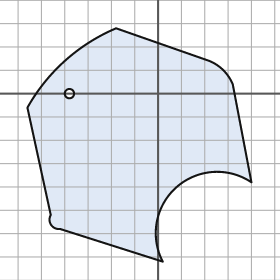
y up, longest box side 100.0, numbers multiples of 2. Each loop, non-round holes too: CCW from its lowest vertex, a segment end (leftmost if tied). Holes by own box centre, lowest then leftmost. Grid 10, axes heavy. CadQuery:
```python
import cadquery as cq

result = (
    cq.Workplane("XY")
    .moveTo(2.0, -72.0)
    .threePointArc((8.0, -40.0), (40.0, -38.0))
    .lineTo(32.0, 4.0)
    .threePointArc((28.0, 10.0), (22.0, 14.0))
    .lineTo(-18.0, 28.0)
    .threePointArc((-40.0, 14.0), (-56.0, -6.0))
    .lineTo(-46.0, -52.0)
    .threePointArc((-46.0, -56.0), (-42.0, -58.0))
    .close()
    .moveTo(-38.0, 0.0)
    .circle(2.0)
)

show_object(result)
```